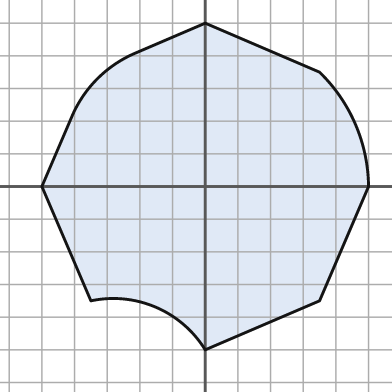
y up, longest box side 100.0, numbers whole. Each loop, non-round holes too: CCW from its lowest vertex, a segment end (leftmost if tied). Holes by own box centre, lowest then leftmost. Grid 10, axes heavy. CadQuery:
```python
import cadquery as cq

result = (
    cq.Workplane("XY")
    .moveTo(0.0, -50.0)
    .lineTo(35.0, -35.0)
    .lineTo(50.0, 0.0)
    .threePointArc((46.0, 19.0), (35.0, 35.0))
    .lineTo(0.0, 50.0)
    .lineTo(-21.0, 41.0)
    .threePointArc((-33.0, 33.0), (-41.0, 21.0))
    .lineTo(-50.0, 0.0)
    .lineTo(-35.0, -35.0)
    .threePointArc((-15.0, -37.0), (0.0, -50.0))
    .close()
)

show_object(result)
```